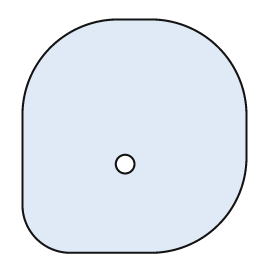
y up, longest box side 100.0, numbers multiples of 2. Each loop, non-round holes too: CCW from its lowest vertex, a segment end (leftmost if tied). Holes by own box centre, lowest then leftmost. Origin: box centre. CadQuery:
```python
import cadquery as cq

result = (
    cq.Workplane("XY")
    .moveTo(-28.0, -50.0)
    .lineTo(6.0, -50.0)
    .threePointArc((36.0, -38.0), (48.0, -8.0))
    .lineTo(48.0, 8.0)
    .threePointArc((36.0, 38.0), (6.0, 50.0))
    .lineTo(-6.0, 50.0)
    .threePointArc((-36.0, 38.0), (-48.0, 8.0))
    .lineTo(-48.0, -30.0)
    .threePointArc((-42.0, -44.0), (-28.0, -50.0))
    .close()
    .moveTo(-4.0, -12.0)
    .circle(4.0)
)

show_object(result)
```